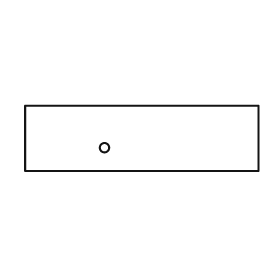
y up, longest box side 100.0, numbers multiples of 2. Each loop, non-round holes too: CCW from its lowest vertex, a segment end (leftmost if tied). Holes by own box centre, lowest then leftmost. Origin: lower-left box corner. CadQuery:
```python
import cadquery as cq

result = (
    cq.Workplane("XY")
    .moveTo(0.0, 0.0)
    .lineTo(100.0, 0.0)
    .lineTo(100.0, 28.0)
    .lineTo(0.0, 28.0)
    .close()
    .moveTo(34.0, 10.0)
    .circle(2.0)
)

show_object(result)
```